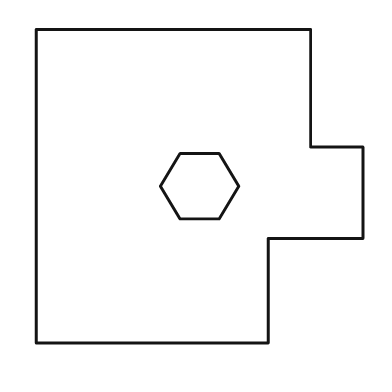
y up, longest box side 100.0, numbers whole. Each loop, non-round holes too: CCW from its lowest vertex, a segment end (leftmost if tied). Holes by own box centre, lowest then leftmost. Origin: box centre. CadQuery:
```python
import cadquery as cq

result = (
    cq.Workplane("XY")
    .moveTo(-50.0, -48.0)
    .lineTo(21.0, -48.0)
    .lineTo(21.0, -16.0)
    .lineTo(50.0, -16.0)
    .lineTo(50.0, 12.0)
    .lineTo(34.0, 12.0)
    .lineTo(34.0, 48.0)
    .lineTo(-50.0, 48.0)
    .close()
    .moveTo(-6.0, -10.0)
    .lineTo(6.0, -10.0)
    .lineTo(12.0, 0.0)
    .lineTo(6.0, 10.0)
    .lineTo(-6.0, 10.0)
    .lineTo(-12.0, 0.0)
    .close()
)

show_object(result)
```